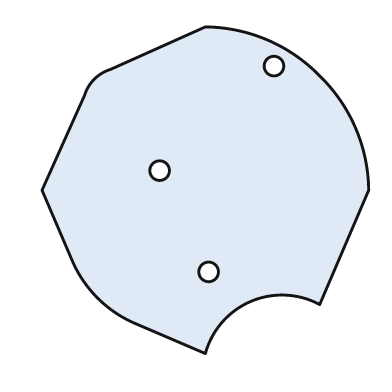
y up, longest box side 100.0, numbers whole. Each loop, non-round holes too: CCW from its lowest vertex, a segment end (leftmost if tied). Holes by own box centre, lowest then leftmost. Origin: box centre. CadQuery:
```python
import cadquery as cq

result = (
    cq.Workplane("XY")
    .moveTo(0.0, -50.0)
    .threePointArc((14.0, -34.0), (35.0, -35.0))
    .lineTo(50.0, 0.0)
    .threePointArc((46.0, 19.0), (35.0, 35.0))
    .threePointArc((19.0, 46.0), (0.0, 50.0))
    .lineTo(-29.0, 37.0)
    .threePointArc((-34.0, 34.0), (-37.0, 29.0))
    .lineTo(-50.0, 0.0)
    .lineTo(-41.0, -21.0)
    .threePointArc((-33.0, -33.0), (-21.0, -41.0))
    .close()
    .moveTo(1.0, -25.0)
    .circle(3.0)
    .moveTo(-14.0, 6.0)
    .circle(3.0)
    .moveTo(21.0, 38.0)
    .circle(3.0)
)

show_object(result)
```